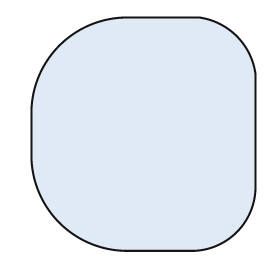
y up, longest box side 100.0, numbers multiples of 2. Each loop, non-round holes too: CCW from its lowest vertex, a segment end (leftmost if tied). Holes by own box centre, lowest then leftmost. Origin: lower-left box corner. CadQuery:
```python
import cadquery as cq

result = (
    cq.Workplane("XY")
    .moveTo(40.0, 0.0)
    .lineTo(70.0, 0.0)
    .threePointArc((88.0, 8.0), (96.0, 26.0))
    .lineTo(96.0, 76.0)
    .threePointArc((88.0, 92.0), (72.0, 100.0))
    .lineTo(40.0, 100.0)
    .threePointArc((12.0, 88.0), (0.0, 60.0))
    .lineTo(0.0, 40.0)
    .threePointArc((12.0, 12.0), (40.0, 0.0))
    .close()
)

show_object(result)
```